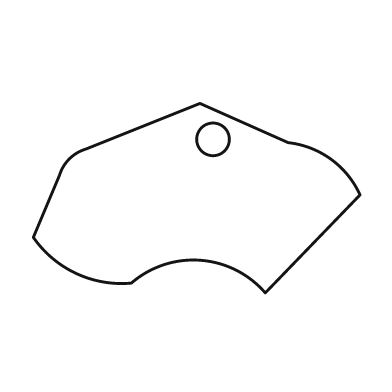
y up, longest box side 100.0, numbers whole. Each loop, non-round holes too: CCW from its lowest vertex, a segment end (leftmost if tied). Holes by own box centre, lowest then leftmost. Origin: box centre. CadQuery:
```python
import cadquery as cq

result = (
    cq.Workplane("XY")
    .moveTo(21.0, -29.0)
    .lineTo(50.0, 1.0)
    .threePointArc((41.0, 12.0), (28.0, 17.0))
    .lineTo(1.0, 29.0)
    .lineTo(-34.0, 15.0)
    .threePointArc((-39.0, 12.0), (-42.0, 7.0))
    .lineTo(-50.0, -12.0)
    .threePointArc((-37.0, -23.0), (-20.0, -26.0))
    .threePointArc((1.0, -19.0), (21.0, -29.0))
    .close()
    .moveTo(5.0, 18.0)
    .circle(5.0)
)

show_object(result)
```